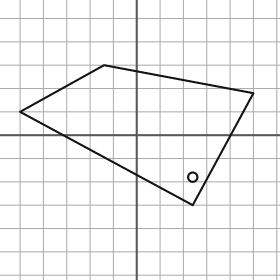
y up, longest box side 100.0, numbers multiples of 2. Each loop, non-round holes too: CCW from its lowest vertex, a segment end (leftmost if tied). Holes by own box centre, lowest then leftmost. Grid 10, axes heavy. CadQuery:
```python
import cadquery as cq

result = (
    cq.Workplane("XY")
    .moveTo(24.0, -30.0)
    .lineTo(50.0, 18.0)
    .lineTo(-14.0, 30.0)
    .lineTo(-50.0, 10.0)
    .close()
    .moveTo(24.0, -18.0)
    .circle(2.0)
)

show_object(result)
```